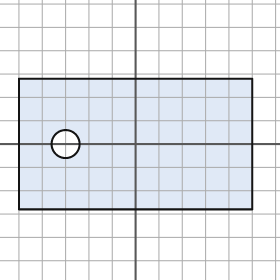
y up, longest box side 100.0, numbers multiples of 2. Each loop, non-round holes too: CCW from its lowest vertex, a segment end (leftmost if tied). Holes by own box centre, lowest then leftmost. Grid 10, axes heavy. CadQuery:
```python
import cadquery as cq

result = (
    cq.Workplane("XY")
    .moveTo(-50.0, -28.0)
    .lineTo(50.0, -28.0)
    .lineTo(50.0, 28.0)
    .lineTo(-50.0, 28.0)
    .close()
    .moveTo(-30.0, 0.0)
    .circle(6.0)
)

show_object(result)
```